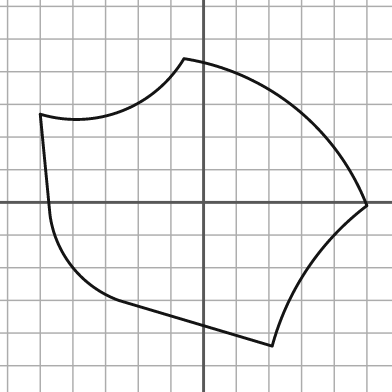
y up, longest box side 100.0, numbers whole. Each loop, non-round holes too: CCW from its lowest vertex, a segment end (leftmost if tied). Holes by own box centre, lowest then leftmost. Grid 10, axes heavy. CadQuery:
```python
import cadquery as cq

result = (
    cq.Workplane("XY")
    .moveTo(21.0, -44.0)
    .threePointArc((32.0, -20.0), (50.0, -1.0))
    .threePointArc((28.0, 29.0), (-6.0, 44.0))
    .threePointArc((-25.0, 28.0), (-50.0, 27.0))
    .lineTo(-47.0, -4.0)
    .threePointArc((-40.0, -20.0), (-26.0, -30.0))
    .close()
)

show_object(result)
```